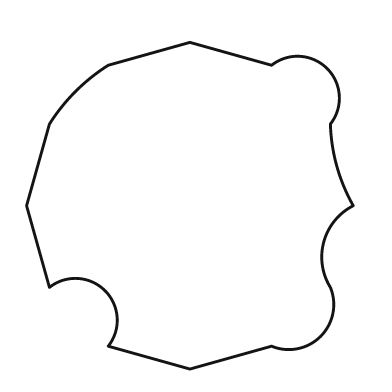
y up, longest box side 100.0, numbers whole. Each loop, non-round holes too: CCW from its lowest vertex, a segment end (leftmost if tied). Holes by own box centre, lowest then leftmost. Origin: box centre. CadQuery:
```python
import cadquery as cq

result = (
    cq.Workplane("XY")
    .moveTo(0.0, -50.0)
    .lineTo(25.0, -43.0)
    .threePointArc((40.0, -40.0), (43.0, -25.0))
    .threePointArc((41.0, -11.0), (50.0, 0.0))
    .threePointArc((45.0, 12.0), (43.0, 25.0))
    .threePointArc((42.0, 42.0), (25.0, 43.0))
    .lineTo(0.0, 50.0)
    .lineTo(-25.0, 43.0)
    .threePointArc((-35.0, 35.0), (-43.0, 25.0))
    .lineTo(-50.0, 0.0)
    .lineTo(-43.0, -25.0)
    .threePointArc((-26.0, -26.0), (-25.0, -43.0))
    .close()
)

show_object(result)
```